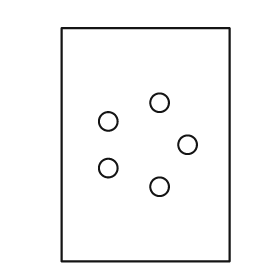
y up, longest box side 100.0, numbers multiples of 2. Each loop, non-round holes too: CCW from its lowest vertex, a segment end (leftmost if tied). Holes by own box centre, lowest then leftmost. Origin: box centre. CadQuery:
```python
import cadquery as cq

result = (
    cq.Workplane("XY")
    .moveTo(-36.0, -50.0)
    .lineTo(36.0, -50.0)
    .lineTo(36.0, 50.0)
    .lineTo(-36.0, 50.0)
    .close()
    .moveTo(6.0, -18.0)
    .circle(4.0)
    .moveTo(-16.0, -10.0)
    .circle(4.0)
    .moveTo(18.0, 0.0)
    .circle(4.0)
    .moveTo(-16.0, 10.0)
    .circle(4.0)
    .moveTo(6.0, 18.0)
    .circle(4.0)
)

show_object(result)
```